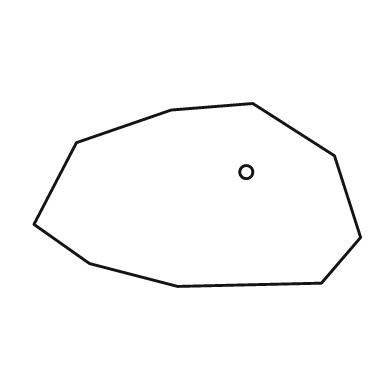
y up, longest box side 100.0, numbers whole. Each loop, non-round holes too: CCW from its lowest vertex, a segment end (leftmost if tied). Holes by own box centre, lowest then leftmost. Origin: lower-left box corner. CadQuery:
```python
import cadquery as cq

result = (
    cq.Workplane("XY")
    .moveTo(44.0, 0.0)
    .lineTo(88.0, 1.0)
    .lineTo(100.0, 15.0)
    .lineTo(92.0, 40.0)
    .lineTo(67.0, 56.0)
    .lineTo(42.0, 54.0)
    .lineTo(13.0, 44.0)
    .lineTo(0.0, 19.0)
    .lineTo(17.0, 7.0)
    .close()
    .moveTo(65.0, 35.0)
    .circle(2.0)
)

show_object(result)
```